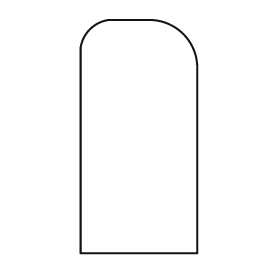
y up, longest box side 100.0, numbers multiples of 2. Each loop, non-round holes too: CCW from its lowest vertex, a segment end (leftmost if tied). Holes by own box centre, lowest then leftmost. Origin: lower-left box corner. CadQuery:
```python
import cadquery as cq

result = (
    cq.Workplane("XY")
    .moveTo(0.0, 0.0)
    .lineTo(50.0, 0.0)
    .lineTo(50.0, 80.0)
    .threePointArc((44.0, 94.0), (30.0, 100.0))
    .lineTo(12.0, 100.0)
    .threePointArc((4.0, 96.0), (0.0, 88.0))
    .close()
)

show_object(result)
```